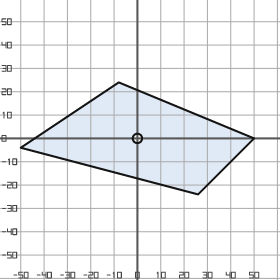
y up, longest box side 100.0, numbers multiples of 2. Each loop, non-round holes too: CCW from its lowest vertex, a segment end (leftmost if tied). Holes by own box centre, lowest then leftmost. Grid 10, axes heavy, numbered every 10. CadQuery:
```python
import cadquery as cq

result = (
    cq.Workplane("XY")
    .moveTo(26.0, -24.0)
    .lineTo(50.0, 0.0)
    .lineTo(-8.0, 24.0)
    .lineTo(-50.0, -4.0)
    .close()
    .moveTo(0.0, 0.0)
    .circle(2.0)
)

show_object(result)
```